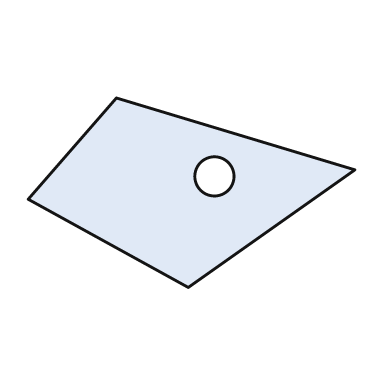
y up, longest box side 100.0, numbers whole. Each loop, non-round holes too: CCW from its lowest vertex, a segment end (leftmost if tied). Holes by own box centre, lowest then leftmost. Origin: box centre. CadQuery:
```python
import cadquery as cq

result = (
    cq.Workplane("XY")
    .moveTo(-1.0, -29.0)
    .lineTo(50.0, 7.0)
    .lineTo(-23.0, 29.0)
    .lineTo(-50.0, -2.0)
    .close()
    .moveTo(7.0, 5.0)
    .circle(6.0)
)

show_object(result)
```